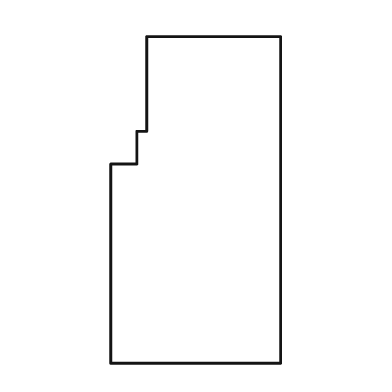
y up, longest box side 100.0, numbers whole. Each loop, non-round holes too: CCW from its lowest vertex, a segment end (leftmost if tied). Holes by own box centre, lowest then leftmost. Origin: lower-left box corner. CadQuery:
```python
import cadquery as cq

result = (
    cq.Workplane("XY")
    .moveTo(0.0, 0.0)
    .lineTo(52.0, 0.0)
    .lineTo(52.0, 100.0)
    .lineTo(11.0, 100.0)
    .lineTo(11.0, 71.0)
    .lineTo(8.0, 71.0)
    .lineTo(8.0, 61.0)
    .lineTo(0.0, 61.0)
    .close()
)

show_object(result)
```